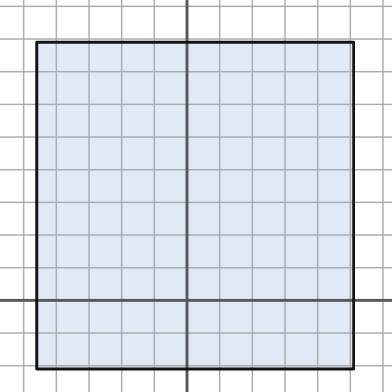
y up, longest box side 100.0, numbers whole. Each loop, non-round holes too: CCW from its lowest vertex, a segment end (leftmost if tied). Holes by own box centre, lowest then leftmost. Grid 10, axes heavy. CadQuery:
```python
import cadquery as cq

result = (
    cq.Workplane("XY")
    .moveTo(-46.0, -21.0)
    .lineTo(51.0, -21.0)
    .lineTo(51.0, 79.0)
    .lineTo(-46.0, 79.0)
    .close()
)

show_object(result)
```